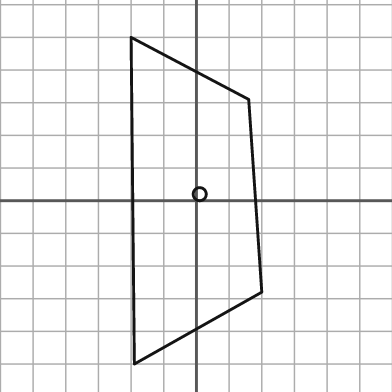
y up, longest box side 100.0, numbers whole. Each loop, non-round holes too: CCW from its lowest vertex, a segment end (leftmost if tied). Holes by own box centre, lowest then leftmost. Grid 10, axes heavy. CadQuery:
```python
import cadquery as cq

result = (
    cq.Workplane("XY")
    .moveTo(-19.0, -50.0)
    .lineTo(20.0, -28.0)
    .lineTo(16.0, 31.0)
    .lineTo(-20.0, 50.0)
    .close()
    .moveTo(1.0, 2.0)
    .circle(2.0)
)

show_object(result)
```